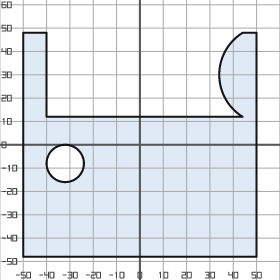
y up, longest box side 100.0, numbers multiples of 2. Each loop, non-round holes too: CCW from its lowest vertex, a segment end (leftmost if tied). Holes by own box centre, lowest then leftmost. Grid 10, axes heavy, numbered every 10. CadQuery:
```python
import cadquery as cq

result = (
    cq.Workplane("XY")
    .moveTo(-50.0, -48.0)
    .lineTo(50.0, -48.0)
    .lineTo(50.0, 48.0)
    .lineTo(44.0, 48.0)
    .threePointArc((34.0, 30.0), (44.0, 12.0))
    .lineTo(-40.0, 12.0)
    .lineTo(-40.0, 48.0)
    .lineTo(-50.0, 48.0)
    .close()
    .moveTo(-32.0, -8.0)
    .circle(8.0)
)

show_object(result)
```